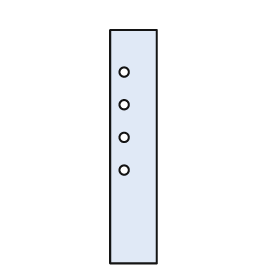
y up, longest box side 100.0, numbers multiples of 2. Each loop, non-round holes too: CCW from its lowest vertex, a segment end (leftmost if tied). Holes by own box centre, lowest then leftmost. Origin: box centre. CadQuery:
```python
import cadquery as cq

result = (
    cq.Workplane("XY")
    .moveTo(-10.0, -50.0)
    .lineTo(10.0, -50.0)
    .lineTo(10.0, 50.0)
    .lineTo(-10.0, 50.0)
    .close()
    .moveTo(-4.0, -10.0)
    .circle(2.0)
    .moveTo(-4.0, 4.0)
    .circle(2.0)
    .moveTo(-4.0, 18.0)
    .circle(2.0)
    .moveTo(-4.0, 32.0)
    .circle(2.0)
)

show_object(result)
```